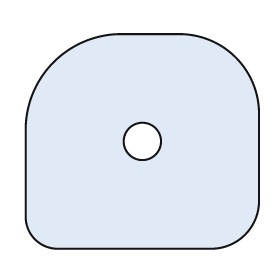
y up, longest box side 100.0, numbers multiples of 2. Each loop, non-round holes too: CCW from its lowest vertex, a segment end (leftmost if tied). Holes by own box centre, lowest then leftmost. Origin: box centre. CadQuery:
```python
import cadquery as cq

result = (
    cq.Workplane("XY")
    .moveTo(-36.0, -46.0)
    .lineTo(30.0, -46.0)
    .threePointArc((44.0, -40.0), (50.0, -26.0))
    .lineTo(50.0, 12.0)
    .threePointArc((40.0, 36.0), (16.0, 46.0))
    .lineTo(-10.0, 46.0)
    .threePointArc((-38.0, 34.0), (-50.0, 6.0))
    .lineTo(-50.0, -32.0)
    .threePointArc((-46.0, -42.0), (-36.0, -46.0))
    .close()
    .moveTo(0.0, 0.0)
    .circle(8.0)
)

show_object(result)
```